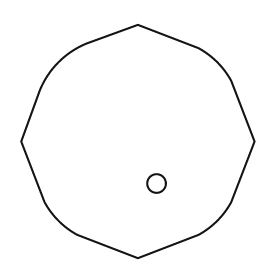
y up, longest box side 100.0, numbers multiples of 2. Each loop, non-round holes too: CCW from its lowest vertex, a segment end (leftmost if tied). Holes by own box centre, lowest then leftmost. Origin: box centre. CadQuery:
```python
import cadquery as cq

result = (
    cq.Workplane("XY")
    .moveTo(0.0, -50.0)
    .lineTo(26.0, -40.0)
    .threePointArc((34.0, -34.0), (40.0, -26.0))
    .lineTo(50.0, 0.0)
    .lineTo(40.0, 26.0)
    .threePointArc((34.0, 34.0), (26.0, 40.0))
    .lineTo(0.0, 50.0)
    .lineTo(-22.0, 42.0)
    .threePointArc((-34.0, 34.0), (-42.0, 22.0))
    .lineTo(-50.0, 0.0)
    .lineTo(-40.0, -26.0)
    .threePointArc((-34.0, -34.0), (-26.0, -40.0))
    .close()
    .moveTo(8.0, -18.0)
    .circle(4.0)
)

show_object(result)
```